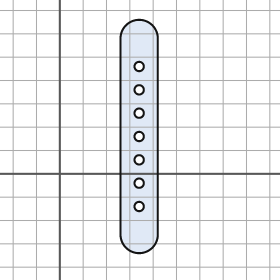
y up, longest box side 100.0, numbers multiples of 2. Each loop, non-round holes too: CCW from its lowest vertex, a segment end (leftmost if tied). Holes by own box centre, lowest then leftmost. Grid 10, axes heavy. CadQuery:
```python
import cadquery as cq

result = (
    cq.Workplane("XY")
    .moveTo(26.0, -26.0)
    .threePointArc((34.0, -34.0), (42.0, -26.0))
    .lineTo(42.0, 58.0)
    .threePointArc((34.0, 66.0), (26.0, 58.0))
    .close()
    .moveTo(34.0, -14.0)
    .circle(2.0)
    .moveTo(34.0, -4.0)
    .circle(2.0)
    .moveTo(34.0, 6.0)
    .circle(2.0)
    .moveTo(34.0, 16.0)
    .circle(2.0)
    .moveTo(34.0, 26.0)
    .circle(2.0)
    .moveTo(34.0, 36.0)
    .circle(2.0)
    .moveTo(34.0, 46.0)
    .circle(2.0)
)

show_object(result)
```